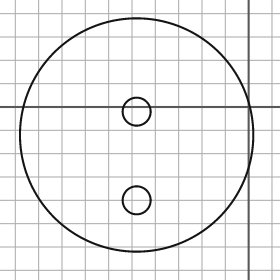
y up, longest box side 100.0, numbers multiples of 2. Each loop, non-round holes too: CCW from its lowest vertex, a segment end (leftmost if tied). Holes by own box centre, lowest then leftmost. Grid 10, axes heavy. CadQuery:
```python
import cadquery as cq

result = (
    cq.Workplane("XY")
    .moveTo(-48.0, -12.0)
    .circle(50.0)
    .moveTo(-48.0, -40.0)
    .circle(6.0)
    .moveTo(-48.0, -2.0)
    .circle(6.0)
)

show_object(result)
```